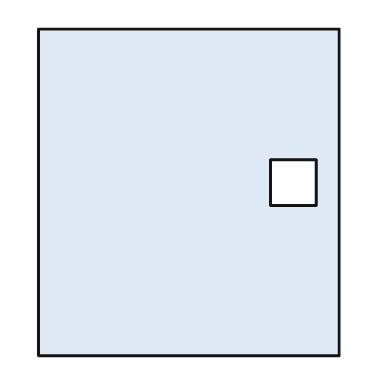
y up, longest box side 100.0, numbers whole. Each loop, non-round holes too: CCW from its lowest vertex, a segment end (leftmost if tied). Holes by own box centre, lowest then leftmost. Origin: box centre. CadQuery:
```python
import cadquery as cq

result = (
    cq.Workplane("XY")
    .moveTo(-46.0, -50.0)
    .lineTo(46.0, -50.0)
    .lineTo(46.0, 50.0)
    .lineTo(-46.0, 50.0)
    .close()
    .moveTo(25.0, -4.0)
    .lineTo(39.0, -4.0)
    .lineTo(39.0, 10.0)
    .lineTo(25.0, 10.0)
    .close()
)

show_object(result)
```